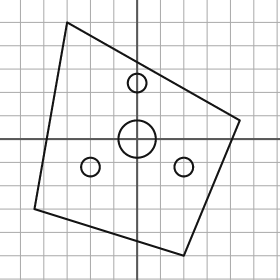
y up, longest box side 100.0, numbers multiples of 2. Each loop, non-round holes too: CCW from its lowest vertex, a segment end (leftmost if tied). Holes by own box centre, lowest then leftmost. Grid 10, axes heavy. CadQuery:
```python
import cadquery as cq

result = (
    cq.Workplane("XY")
    .moveTo(20.0, -50.0)
    .lineTo(44.0, 8.0)
    .lineTo(-30.0, 50.0)
    .lineTo(-44.0, -30.0)
    .close()
    .moveTo(-20.0, -12.0)
    .circle(4.0)
    .moveTo(20.0, -12.0)
    .circle(4.0)
    .moveTo(0.0, 0.0)
    .circle(8.0)
    .moveTo(0.0, 24.0)
    .circle(4.0)
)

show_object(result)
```